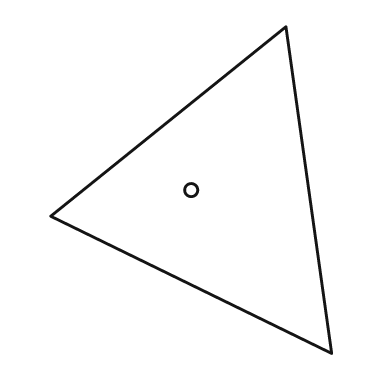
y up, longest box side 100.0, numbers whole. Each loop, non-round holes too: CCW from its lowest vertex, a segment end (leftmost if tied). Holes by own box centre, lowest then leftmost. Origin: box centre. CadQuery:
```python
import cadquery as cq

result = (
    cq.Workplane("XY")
    .moveTo(43.0, -50.0)
    .lineTo(29.0, 50.0)
    .lineTo(-43.0, -8.0)
    .close()
    .moveTo(0.0, 0.0)
    .circle(2.0)
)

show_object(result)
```